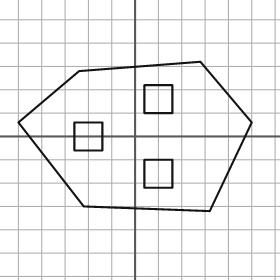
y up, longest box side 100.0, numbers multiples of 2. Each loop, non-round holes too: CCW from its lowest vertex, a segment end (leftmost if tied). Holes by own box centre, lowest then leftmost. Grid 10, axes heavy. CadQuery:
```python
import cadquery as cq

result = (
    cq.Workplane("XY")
    .moveTo(32.0, -32.0)
    .lineTo(50.0, 6.0)
    .lineTo(28.0, 32.0)
    .lineTo(-24.0, 28.0)
    .lineTo(-50.0, 6.0)
    .lineTo(-22.0, -30.0)
    .close()
    .moveTo(4.0, -22.0)
    .lineTo(16.0, -22.0)
    .lineTo(16.0, -10.0)
    .lineTo(4.0, -10.0)
    .close()
    .moveTo(-26.0, -6.0)
    .lineTo(-14.0, -6.0)
    .lineTo(-14.0, 6.0)
    .lineTo(-26.0, 6.0)
    .close()
    .moveTo(4.0, 10.0)
    .lineTo(16.0, 10.0)
    .lineTo(16.0, 22.0)
    .lineTo(4.0, 22.0)
    .close()
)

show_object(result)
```